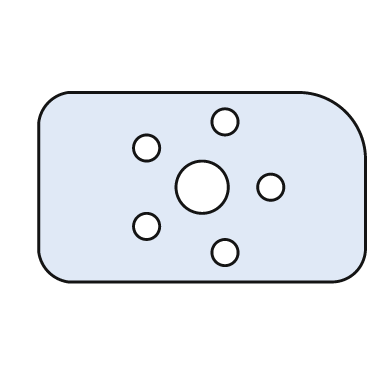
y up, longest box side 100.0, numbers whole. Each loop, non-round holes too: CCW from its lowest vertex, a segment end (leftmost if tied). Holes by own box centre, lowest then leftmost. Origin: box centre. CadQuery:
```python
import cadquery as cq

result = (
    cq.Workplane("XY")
    .moveTo(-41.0, -29.0)
    .lineTo(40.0, -29.0)
    .threePointArc((47.0, -26.0), (50.0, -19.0))
    .lineTo(50.0, 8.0)
    .threePointArc((44.0, 23.0), (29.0, 29.0))
    .lineTo(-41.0, 29.0)
    .threePointArc((-47.0, 26.0), (-50.0, 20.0))
    .lineTo(-50.0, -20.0)
    .threePointArc((-47.0, -26.0), (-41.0, -29.0))
    .close()
    .moveTo(7.0, -20.0)
    .circle(4.0)
    .moveTo(-17.0, -12.0)
    .circle(4.0)
    .moveTo(0.0, 0.0)
    .circle(8.0)
    .moveTo(21.0, 0.0)
    .circle(4.0)
    .moveTo(-17.0, 12.0)
    .circle(4.0)
    .moveTo(7.0, 20.0)
    .circle(4.0)
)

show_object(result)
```